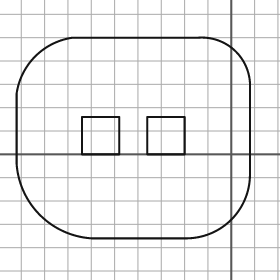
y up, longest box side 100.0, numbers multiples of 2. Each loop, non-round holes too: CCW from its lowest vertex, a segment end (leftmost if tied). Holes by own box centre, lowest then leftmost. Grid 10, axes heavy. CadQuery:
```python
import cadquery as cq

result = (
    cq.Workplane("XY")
    .moveTo(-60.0, -36.0)
    .lineTo(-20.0, -36.0)
    .threePointArc((0.0, -28.0), (8.0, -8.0))
    .lineTo(8.0, 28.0)
    .threePointArc((2.0, 44.0), (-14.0, 50.0))
    .lineTo(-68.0, 50.0)
    .threePointArc((-84.0, 42.0), (-92.0, 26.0))
    .lineTo(-92.0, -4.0)
    .threePointArc((-82.0, -26.0), (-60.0, -36.0))
    .close()
    .moveTo(-64.0, 0.0)
    .lineTo(-48.0, 0.0)
    .lineTo(-48.0, 16.0)
    .lineTo(-64.0, 16.0)
    .close()
    .moveTo(-36.0, 0.0)
    .lineTo(-20.0, 0.0)
    .lineTo(-20.0, 16.0)
    .lineTo(-36.0, 16.0)
    .close()
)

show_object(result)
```